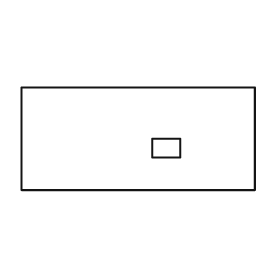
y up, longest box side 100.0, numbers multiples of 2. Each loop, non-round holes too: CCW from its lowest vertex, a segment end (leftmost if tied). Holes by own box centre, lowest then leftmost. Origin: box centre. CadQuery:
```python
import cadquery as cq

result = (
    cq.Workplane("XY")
    .moveTo(-50.0, -22.0)
    .lineTo(50.0, -22.0)
    .lineTo(50.0, 22.0)
    .lineTo(-50.0, 22.0)
    .close()
    .moveTo(6.0, -8.0)
    .lineTo(18.0, -8.0)
    .lineTo(18.0, 0.0)
    .lineTo(6.0, 0.0)
    .close()
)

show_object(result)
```